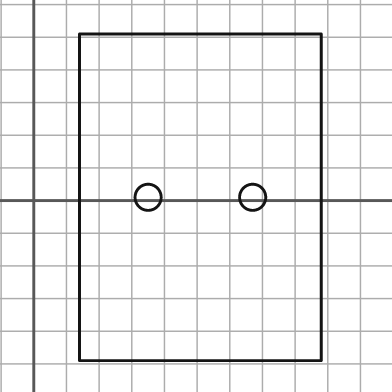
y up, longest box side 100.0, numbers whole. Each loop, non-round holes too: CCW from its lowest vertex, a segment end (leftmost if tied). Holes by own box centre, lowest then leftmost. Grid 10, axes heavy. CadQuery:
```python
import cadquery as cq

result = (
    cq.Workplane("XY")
    .moveTo(14.0, -49.0)
    .lineTo(88.0, -49.0)
    .lineTo(88.0, 51.0)
    .lineTo(14.0, 51.0)
    .close()
    .moveTo(35.0, 1.0)
    .circle(4.0)
    .moveTo(67.0, 1.0)
    .circle(4.0)
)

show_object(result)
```